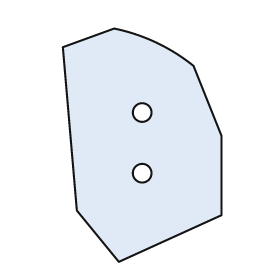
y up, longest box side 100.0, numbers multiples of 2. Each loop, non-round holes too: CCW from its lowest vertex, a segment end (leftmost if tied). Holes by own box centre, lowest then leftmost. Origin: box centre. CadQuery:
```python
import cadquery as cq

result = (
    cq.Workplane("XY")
    .moveTo(-10.0, -50.0)
    .lineTo(34.0, -30.0)
    .lineTo(34.0, 4.0)
    .lineTo(22.0, 34.0)
    .threePointArc((6.0, 44.0), (-12.0, 50.0))
    .lineTo(-34.0, 42.0)
    .lineTo(-28.0, -28.0)
    .close()
    .moveTo(0.0, -12.0)
    .circle(4.0)
    .moveTo(0.0, 14.0)
    .circle(4.0)
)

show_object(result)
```